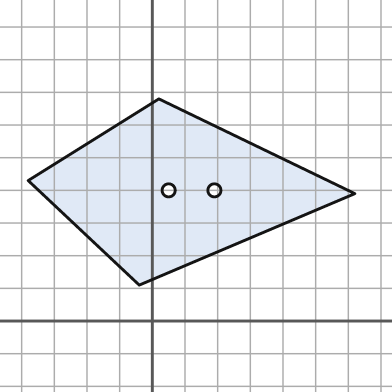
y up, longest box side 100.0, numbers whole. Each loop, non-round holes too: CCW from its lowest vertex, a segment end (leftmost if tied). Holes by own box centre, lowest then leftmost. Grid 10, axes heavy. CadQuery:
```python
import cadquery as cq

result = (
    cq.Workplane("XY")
    .moveTo(-4.0, 11.0)
    .lineTo(62.0, 39.0)
    .lineTo(2.0, 68.0)
    .lineTo(-38.0, 43.0)
    .close()
    .moveTo(5.0, 40.0)
    .circle(2.0)
    .moveTo(19.0, 40.0)
    .circle(2.0)
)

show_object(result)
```